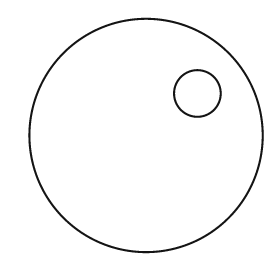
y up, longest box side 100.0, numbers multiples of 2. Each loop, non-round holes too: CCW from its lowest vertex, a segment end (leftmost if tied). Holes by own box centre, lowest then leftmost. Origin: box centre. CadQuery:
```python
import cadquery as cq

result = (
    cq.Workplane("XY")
    .moveTo(0.0, 0.0)
    .circle(50.0)
    .moveTo(22.0, 18.0)
    .circle(10.0)
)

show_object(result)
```